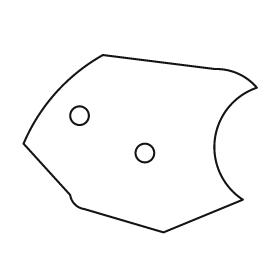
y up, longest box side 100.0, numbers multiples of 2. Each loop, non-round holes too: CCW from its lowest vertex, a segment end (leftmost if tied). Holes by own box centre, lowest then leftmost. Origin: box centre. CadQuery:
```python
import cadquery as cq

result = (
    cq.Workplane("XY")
    .moveTo(10.0, -38.0)
    .lineTo(44.0, -24.0)
    .threePointArc((32.0, 2.0), (50.0, 24.0))
    .threePointArc((42.0, 30.0), (32.0, 32.0))
    .lineTo(-16.0, 38.0)
    .threePointArc((-36.0, 22.0), (-50.0, 0.0))
    .lineTo(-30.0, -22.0)
    .threePointArc((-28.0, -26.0), (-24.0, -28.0))
    .close()
    .moveTo(2.0, -4.0)
    .circle(4.0)
    .moveTo(-26.0, 12.0)
    .circle(4.0)
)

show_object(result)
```